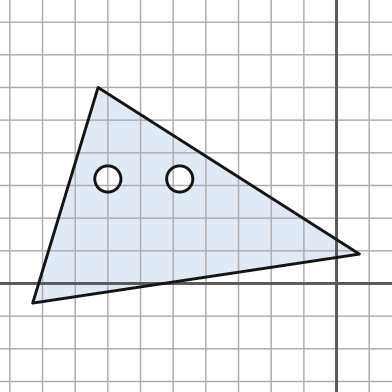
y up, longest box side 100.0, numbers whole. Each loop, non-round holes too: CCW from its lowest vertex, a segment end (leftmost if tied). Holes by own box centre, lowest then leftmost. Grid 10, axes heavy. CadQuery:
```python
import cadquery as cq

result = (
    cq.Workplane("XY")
    .moveTo(-93.0, -6.0)
    .lineTo(7.0, 9.0)
    .lineTo(-73.0, 60.0)
    .close()
    .moveTo(-70.0, 32.0)
    .circle(4.0)
    .moveTo(-48.0, 32.0)
    .circle(4.0)
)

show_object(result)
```